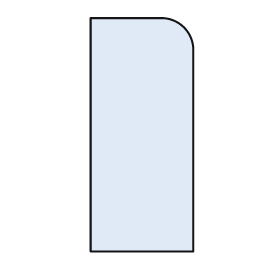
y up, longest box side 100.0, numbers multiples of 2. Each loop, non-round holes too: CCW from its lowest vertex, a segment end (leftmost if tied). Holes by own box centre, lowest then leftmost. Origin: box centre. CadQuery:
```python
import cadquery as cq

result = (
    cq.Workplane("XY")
    .moveTo(-22.0, -50.0)
    .lineTo(22.0, -50.0)
    .lineTo(22.0, 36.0)
    .threePointArc((18.0, 46.0), (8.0, 50.0))
    .lineTo(-22.0, 50.0)
    .close()
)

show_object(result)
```